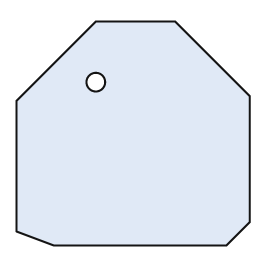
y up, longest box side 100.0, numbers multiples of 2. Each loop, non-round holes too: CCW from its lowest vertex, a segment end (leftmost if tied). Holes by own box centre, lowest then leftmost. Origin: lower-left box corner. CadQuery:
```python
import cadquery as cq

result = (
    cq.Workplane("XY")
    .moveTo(16.0, 0.0)
    .lineTo(90.0, 0.0)
    .lineTo(100.0, 10.0)
    .lineTo(100.0, 64.0)
    .lineTo(68.0, 96.0)
    .lineTo(34.0, 96.0)
    .lineTo(0.0, 62.0)
    .lineTo(0.0, 6.0)
    .close()
    .moveTo(34.0, 70.0)
    .circle(4.0)
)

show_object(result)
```